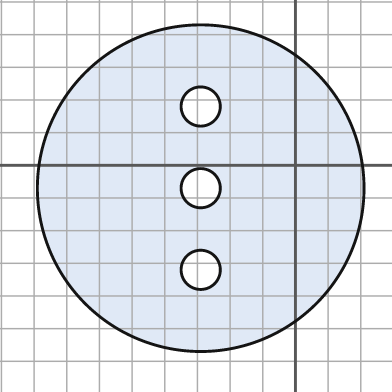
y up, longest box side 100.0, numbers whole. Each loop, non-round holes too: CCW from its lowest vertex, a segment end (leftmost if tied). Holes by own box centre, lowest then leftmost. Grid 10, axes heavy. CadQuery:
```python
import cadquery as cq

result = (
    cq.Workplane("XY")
    .moveTo(-29.0, -7.0)
    .circle(50.0)
    .moveTo(-29.0, -32.0)
    .circle(6.0)
    .moveTo(-29.0, -7.0)
    .circle(6.0)
    .moveTo(-29.0, 18.0)
    .circle(6.0)
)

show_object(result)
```